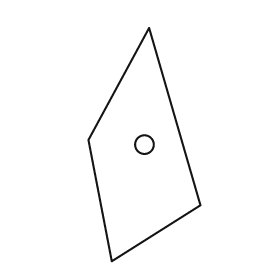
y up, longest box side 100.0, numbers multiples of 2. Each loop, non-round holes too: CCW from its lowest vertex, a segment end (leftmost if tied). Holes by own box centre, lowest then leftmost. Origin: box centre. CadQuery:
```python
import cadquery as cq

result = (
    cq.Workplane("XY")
    .moveTo(-14.0, -50.0)
    .lineTo(24.0, -26.0)
    .lineTo(2.0, 50.0)
    .lineTo(-24.0, 2.0)
    .close()
    .moveTo(0.0, 0.0)
    .circle(4.0)
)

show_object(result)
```